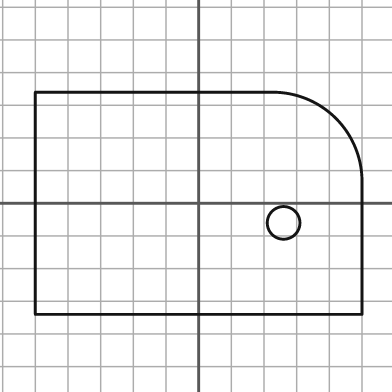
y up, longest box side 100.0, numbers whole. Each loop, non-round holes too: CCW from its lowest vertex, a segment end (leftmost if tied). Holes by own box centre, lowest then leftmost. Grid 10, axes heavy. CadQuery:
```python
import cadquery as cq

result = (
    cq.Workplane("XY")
    .moveTo(-50.0, -34.0)
    .lineTo(50.0, -34.0)
    .lineTo(50.0, 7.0)
    .threePointArc((42.0, 26.0), (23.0, 34.0))
    .lineTo(-50.0, 34.0)
    .close()
    .moveTo(26.0, -6.0)
    .circle(5.0)
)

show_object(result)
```